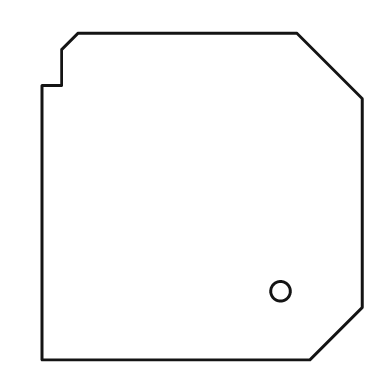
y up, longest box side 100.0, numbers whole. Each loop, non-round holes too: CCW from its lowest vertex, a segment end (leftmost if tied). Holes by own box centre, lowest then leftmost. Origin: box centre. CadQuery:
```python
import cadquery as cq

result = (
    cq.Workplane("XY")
    .moveTo(-49.0, -50.0)
    .lineTo(33.0, -50.0)
    .lineTo(49.0, -34.0)
    .lineTo(49.0, 30.0)
    .lineTo(29.0, 50.0)
    .lineTo(-38.0, 50.0)
    .lineTo(-43.0, 45.0)
    .lineTo(-43.0, 34.0)
    .lineTo(-49.0, 34.0)
    .close()
    .moveTo(24.0, -29.0)
    .circle(3.0)
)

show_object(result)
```